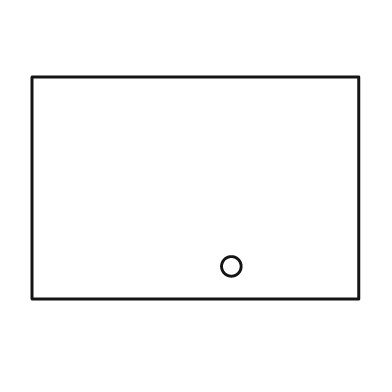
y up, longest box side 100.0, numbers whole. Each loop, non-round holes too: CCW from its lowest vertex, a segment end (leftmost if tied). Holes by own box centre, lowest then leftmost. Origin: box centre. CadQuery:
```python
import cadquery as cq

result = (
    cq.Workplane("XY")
    .moveTo(-50.0, -34.0)
    .lineTo(50.0, -34.0)
    .lineTo(50.0, 34.0)
    .lineTo(-50.0, 34.0)
    .close()
    .moveTo(11.0, -24.0)
    .circle(3.0)
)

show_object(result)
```